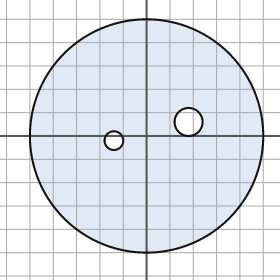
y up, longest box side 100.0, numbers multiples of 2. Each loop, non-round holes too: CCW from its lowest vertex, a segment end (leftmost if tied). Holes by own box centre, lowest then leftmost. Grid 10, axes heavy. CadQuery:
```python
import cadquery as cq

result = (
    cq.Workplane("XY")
    .moveTo(0.0, 0.0)
    .circle(50.0)
    .moveTo(-14.0, -2.0)
    .circle(4.0)
    .moveTo(18.0, 6.0)
    .circle(6.0)
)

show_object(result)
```